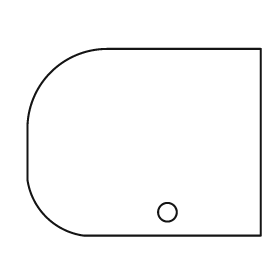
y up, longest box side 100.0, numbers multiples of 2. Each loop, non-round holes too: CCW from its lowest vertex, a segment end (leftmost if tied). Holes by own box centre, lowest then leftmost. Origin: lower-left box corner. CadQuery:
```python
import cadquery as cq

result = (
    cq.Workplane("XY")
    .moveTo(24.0, 0.0)
    .lineTo(100.0, 0.0)
    .lineTo(100.0, 80.0)
    .lineTo(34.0, 80.0)
    .threePointArc((10.0, 70.0), (0.0, 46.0))
    .lineTo(0.0, 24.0)
    .threePointArc((8.0, 8.0), (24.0, 0.0))
    .close()
    .moveTo(60.0, 10.0)
    .circle(4.0)
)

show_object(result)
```